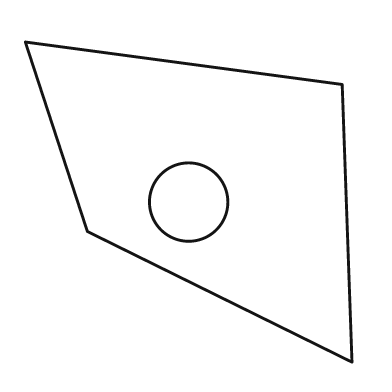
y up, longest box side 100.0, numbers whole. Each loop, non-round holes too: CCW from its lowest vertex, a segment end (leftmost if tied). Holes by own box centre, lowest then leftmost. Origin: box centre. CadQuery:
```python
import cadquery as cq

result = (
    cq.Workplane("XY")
    .moveTo(50.0, -49.0)
    .lineTo(47.0, 36.0)
    .lineTo(-50.0, 49.0)
    .lineTo(-31.0, -9.0)
    .close()
    .moveTo(0.0, 0.0)
    .circle(12.0)
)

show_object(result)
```